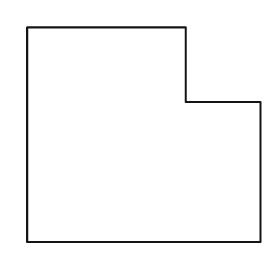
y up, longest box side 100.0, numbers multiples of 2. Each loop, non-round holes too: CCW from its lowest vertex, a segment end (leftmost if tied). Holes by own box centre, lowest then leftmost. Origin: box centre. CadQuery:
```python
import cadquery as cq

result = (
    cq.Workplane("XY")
    .moveTo(-50.0, -46.0)
    .lineTo(50.0, -46.0)
    .lineTo(50.0, 14.0)
    .lineTo(18.0, 14.0)
    .lineTo(18.0, 46.0)
    .lineTo(-50.0, 46.0)
    .close()
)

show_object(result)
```